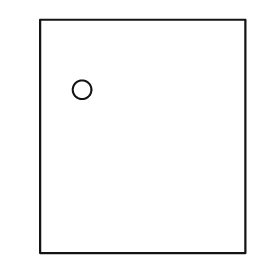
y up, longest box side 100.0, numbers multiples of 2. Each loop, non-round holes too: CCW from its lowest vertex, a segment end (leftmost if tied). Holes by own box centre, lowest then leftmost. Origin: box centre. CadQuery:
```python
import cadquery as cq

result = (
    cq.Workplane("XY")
    .moveTo(-44.0, -50.0)
    .lineTo(44.0, -50.0)
    .lineTo(44.0, 50.0)
    .lineTo(-44.0, 50.0)
    .close()
    .moveTo(-26.0, 20.0)
    .circle(4.0)
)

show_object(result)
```